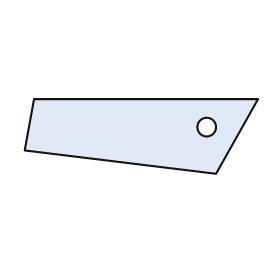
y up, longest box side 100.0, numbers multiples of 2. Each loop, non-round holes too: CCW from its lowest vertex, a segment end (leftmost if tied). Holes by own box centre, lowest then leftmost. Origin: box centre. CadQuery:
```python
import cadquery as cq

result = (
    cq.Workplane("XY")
    .moveTo(32.0, -16.0)
    .lineTo(50.0, 16.0)
    .lineTo(-46.0, 16.0)
    .lineTo(-50.0, -6.0)
    .close()
    .moveTo(28.0, 4.0)
    .circle(4.0)
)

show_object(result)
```